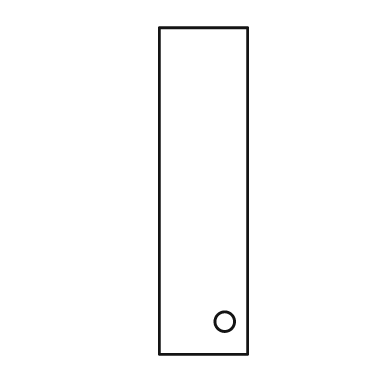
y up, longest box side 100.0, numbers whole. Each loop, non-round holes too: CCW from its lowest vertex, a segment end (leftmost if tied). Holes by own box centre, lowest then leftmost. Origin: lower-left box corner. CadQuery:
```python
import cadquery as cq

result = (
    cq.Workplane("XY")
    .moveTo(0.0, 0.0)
    .lineTo(27.0, 0.0)
    .lineTo(27.0, 100.0)
    .lineTo(0.0, 100.0)
    .close()
    .moveTo(20.0, 10.0)
    .circle(3.0)
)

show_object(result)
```